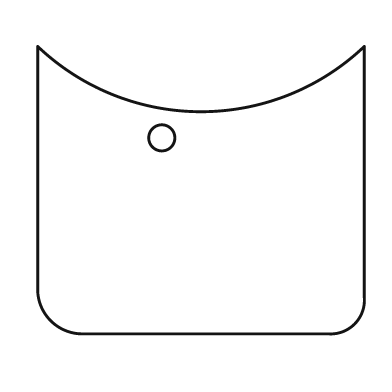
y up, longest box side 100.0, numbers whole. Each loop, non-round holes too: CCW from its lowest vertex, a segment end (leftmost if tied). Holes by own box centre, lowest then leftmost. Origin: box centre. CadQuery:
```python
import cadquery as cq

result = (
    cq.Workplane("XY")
    .moveTo(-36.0, -44.0)
    .lineTo(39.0, -44.0)
    .threePointArc((47.0, -41.0), (50.0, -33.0))
    .lineTo(50.0, 44.0)
    .threePointArc((0.0, 24.0), (-50.0, 44.0))
    .lineTo(-50.0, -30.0)
    .threePointArc((-46.0, -40.0), (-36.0, -44.0))
    .close()
    .moveTo(-12.0, 16.0)
    .circle(4.0)
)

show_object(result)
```